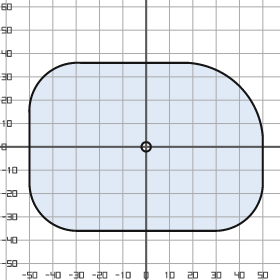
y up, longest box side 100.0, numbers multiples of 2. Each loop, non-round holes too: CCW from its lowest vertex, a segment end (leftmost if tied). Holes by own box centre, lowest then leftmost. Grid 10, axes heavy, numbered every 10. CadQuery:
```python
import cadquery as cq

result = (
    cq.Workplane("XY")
    .moveTo(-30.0, -36.0)
    .lineTo(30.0, -36.0)
    .threePointArc((44.0, -30.0), (50.0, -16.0))
    .lineTo(50.0, 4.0)
    .threePointArc((40.0, 26.0), (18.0, 36.0))
    .lineTo(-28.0, 36.0)
    .threePointArc((-44.0, 30.0), (-50.0, 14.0))
    .lineTo(-50.0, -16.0)
    .threePointArc((-44.0, -30.0), (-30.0, -36.0))
    .close()
    .moveTo(0.0, 0.0)
    .circle(2.0)
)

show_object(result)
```